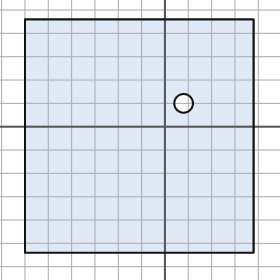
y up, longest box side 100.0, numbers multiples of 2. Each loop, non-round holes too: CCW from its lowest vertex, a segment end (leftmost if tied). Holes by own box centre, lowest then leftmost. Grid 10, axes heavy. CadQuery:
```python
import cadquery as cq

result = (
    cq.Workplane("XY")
    .moveTo(-60.0, -54.0)
    .lineTo(38.0, -54.0)
    .lineTo(38.0, 46.0)
    .lineTo(-60.0, 46.0)
    .close()
    .moveTo(8.0, 10.0)
    .circle(4.0)
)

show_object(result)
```